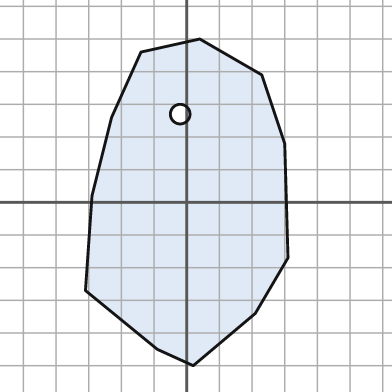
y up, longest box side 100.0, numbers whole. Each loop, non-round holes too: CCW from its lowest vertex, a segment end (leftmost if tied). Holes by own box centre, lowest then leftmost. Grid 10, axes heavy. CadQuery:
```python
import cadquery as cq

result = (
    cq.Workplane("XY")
    .moveTo(2.0, -50.0)
    .lineTo(21.0, -34.0)
    .lineTo(31.0, -17.0)
    .lineTo(30.0, 18.0)
    .lineTo(23.0, 39.0)
    .lineTo(4.0, 50.0)
    .lineTo(-14.0, 46.0)
    .lineTo(-23.0, 26.0)
    .lineTo(-29.0, 2.0)
    .lineTo(-31.0, -27.0)
    .lineTo(-9.0, -45.0)
    .close()
    .moveTo(-2.0, 27.0)
    .circle(3.0)
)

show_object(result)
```